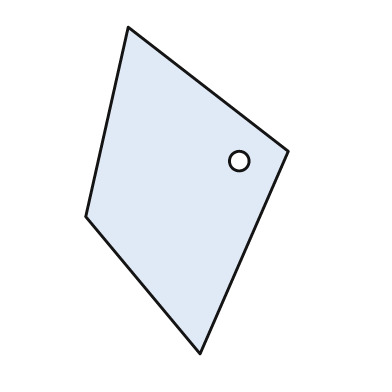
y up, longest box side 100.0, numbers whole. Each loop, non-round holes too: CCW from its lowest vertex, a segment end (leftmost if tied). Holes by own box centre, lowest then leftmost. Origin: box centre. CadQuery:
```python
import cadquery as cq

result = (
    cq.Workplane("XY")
    .moveTo(4.0, -50.0)
    .lineTo(31.0, 12.0)
    .lineTo(-18.0, 50.0)
    .lineTo(-31.0, -8.0)
    .close()
    .moveTo(16.0, 9.0)
    .circle(3.0)
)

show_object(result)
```